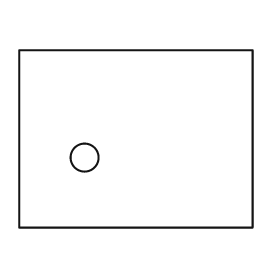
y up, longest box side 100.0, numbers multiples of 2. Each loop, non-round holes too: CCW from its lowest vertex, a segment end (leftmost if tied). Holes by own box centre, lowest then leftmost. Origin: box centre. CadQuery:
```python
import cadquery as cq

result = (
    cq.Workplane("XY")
    .moveTo(-50.0, -38.0)
    .lineTo(50.0, -38.0)
    .lineTo(50.0, 38.0)
    .lineTo(-50.0, 38.0)
    .close()
    .moveTo(-22.0, -8.0)
    .circle(6.0)
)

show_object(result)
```